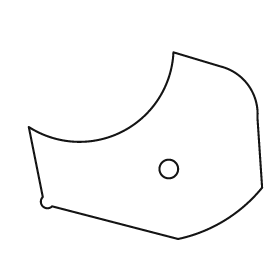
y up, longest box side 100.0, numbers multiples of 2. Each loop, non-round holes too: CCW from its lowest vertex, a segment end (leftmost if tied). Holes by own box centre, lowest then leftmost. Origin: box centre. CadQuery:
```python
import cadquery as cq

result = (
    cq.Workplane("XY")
    .moveTo(14.0, -40.0)
    .threePointArc((34.0, -32.0), (50.0, -18.0))
    .lineTo(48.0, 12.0)
    .threePointArc((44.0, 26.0), (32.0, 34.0))
    .lineTo(12.0, 40.0)
    .threePointArc((-10.0, 6.0), (-50.0, 8.0))
    .lineTo(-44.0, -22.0)
    .threePointArc((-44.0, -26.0), (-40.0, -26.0))
    .close()
    .moveTo(10.0, -10.0)
    .circle(4.0)
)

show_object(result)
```